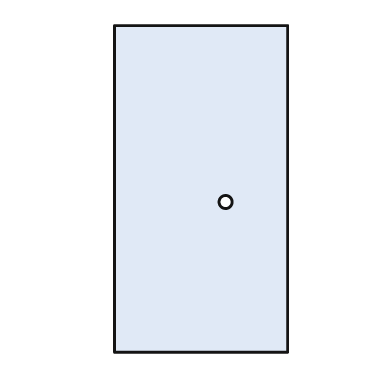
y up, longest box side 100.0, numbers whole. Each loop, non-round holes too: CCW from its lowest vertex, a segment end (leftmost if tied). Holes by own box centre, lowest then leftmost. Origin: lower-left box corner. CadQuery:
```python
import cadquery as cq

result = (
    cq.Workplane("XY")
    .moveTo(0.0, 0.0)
    .lineTo(53.0, 0.0)
    .lineTo(53.0, 100.0)
    .lineTo(0.0, 100.0)
    .close()
    .moveTo(34.0, 46.0)
    .circle(2.0)
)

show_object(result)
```